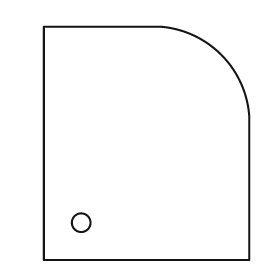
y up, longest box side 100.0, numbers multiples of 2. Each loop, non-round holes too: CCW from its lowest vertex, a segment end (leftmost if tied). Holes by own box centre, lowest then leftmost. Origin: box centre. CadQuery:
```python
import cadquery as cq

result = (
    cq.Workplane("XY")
    .moveTo(-44.0, -50.0)
    .lineTo(44.0, -50.0)
    .lineTo(44.0, 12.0)
    .threePointArc((32.0, 38.0), (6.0, 50.0))
    .lineTo(-44.0, 50.0)
    .close()
    .moveTo(-28.0, -34.0)
    .circle(4.0)
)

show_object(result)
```